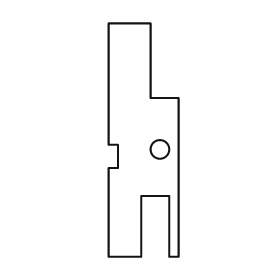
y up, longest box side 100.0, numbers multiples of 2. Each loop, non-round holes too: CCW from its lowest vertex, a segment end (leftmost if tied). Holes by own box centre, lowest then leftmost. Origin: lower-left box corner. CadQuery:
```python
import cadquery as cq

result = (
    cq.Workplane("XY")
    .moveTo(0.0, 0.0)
    .lineTo(14.0, 0.0)
    .lineTo(14.0, 26.0)
    .lineTo(26.0, 26.0)
    .lineTo(26.0, 0.0)
    .lineTo(30.0, 0.0)
    .lineTo(30.0, 68.0)
    .lineTo(18.0, 68.0)
    .lineTo(18.0, 100.0)
    .lineTo(0.0, 100.0)
    .lineTo(0.0, 48.0)
    .lineTo(4.0, 48.0)
    .lineTo(4.0, 38.0)
    .lineTo(0.0, 38.0)
    .close()
    .moveTo(22.0, 46.0)
    .circle(4.0)
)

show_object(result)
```